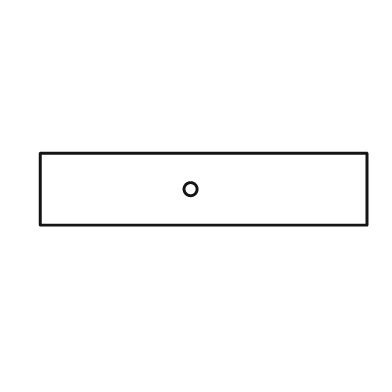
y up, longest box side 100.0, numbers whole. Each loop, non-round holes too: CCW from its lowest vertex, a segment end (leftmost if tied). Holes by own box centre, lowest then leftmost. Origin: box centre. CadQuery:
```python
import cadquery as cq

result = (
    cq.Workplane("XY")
    .moveTo(-50.0, -11.0)
    .lineTo(50.0, -11.0)
    .lineTo(50.0, 11.0)
    .lineTo(-50.0, 11.0)
    .close()
    .moveTo(-4.0, 0.0)
    .circle(2.0)
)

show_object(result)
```